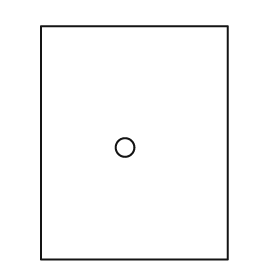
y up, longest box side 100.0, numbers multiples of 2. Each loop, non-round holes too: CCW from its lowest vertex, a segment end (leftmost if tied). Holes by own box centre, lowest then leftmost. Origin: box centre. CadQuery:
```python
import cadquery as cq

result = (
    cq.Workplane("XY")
    .moveTo(-40.0, -50.0)
    .lineTo(40.0, -50.0)
    .lineTo(40.0, 50.0)
    .lineTo(-40.0, 50.0)
    .close()
    .moveTo(-4.0, -2.0)
    .circle(4.0)
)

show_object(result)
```